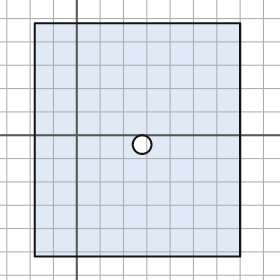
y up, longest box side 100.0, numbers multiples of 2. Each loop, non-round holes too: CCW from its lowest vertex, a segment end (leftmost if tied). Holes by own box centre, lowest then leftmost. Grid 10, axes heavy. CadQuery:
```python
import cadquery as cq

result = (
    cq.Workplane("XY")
    .moveTo(-18.0, -52.0)
    .lineTo(70.0, -52.0)
    .lineTo(70.0, 48.0)
    .lineTo(-18.0, 48.0)
    .close()
    .moveTo(28.0, -4.0)
    .circle(4.0)
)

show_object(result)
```